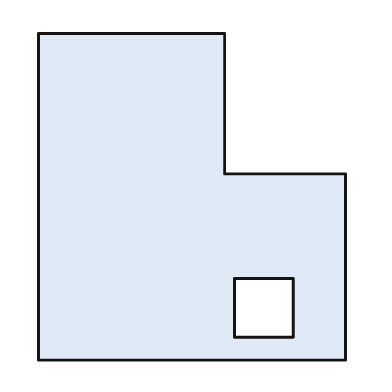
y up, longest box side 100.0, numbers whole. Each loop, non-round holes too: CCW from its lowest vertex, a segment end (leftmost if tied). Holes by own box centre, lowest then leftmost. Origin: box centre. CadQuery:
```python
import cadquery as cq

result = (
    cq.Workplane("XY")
    .moveTo(-47.0, -50.0)
    .lineTo(47.0, -50.0)
    .lineTo(47.0, 7.0)
    .lineTo(10.0, 7.0)
    .lineTo(10.0, 50.0)
    .lineTo(-47.0, 50.0)
    .close()
    .moveTo(13.0, -43.0)
    .lineTo(31.0, -43.0)
    .lineTo(31.0, -25.0)
    .lineTo(13.0, -25.0)
    .close()
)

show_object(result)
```